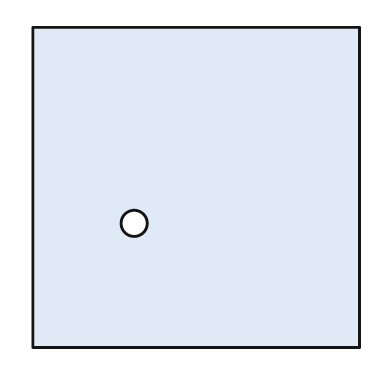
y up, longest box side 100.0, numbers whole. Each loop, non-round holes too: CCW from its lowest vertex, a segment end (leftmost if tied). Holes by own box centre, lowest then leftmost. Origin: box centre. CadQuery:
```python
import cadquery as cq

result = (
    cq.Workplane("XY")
    .moveTo(-50.0, -49.0)
    .lineTo(50.0, -49.0)
    .lineTo(50.0, 49.0)
    .lineTo(-50.0, 49.0)
    .close()
    .moveTo(-19.0, -11.0)
    .circle(4.0)
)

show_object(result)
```